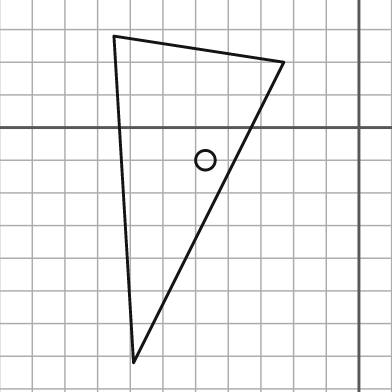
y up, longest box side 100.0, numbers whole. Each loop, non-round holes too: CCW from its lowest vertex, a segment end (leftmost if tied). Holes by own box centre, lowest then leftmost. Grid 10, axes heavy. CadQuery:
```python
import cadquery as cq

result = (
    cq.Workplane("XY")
    .moveTo(-69.0, -72.0)
    .lineTo(-23.0, 20.0)
    .lineTo(-75.0, 28.0)
    .close()
    .moveTo(-47.0, -10.0)
    .circle(3.0)
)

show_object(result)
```